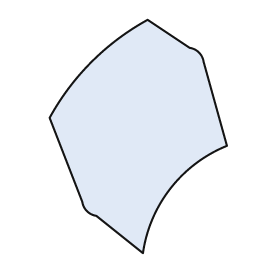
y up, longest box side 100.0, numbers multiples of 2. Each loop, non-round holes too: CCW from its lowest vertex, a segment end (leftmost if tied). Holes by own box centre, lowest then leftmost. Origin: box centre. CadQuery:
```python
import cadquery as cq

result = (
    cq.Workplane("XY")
    .moveTo(2.0, -50.0)
    .threePointArc((14.0, -22.0), (38.0, -4.0))
    .lineTo(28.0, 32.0)
    .threePointArc((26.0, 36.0), (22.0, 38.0))
    .lineTo(4.0, 50.0)
    .threePointArc((-20.0, 32.0), (-38.0, 8.0))
    .lineTo(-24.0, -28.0)
    .threePointArc((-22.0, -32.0), (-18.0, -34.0))
    .close()
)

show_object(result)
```